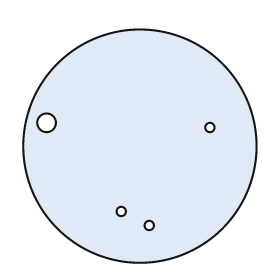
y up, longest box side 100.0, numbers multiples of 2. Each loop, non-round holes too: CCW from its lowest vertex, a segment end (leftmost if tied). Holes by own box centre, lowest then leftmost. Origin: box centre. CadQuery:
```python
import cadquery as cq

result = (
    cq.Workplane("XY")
    .moveTo(0.0, 0.0)
    .circle(50.0)
    .moveTo(4.0, -34.0)
    .circle(2.0)
    .moveTo(-8.0, -28.0)
    .circle(2.0)
    .moveTo(30.0, 8.0)
    .circle(2.0)
    .moveTo(-40.0, 10.0)
    .circle(4.0)
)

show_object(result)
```